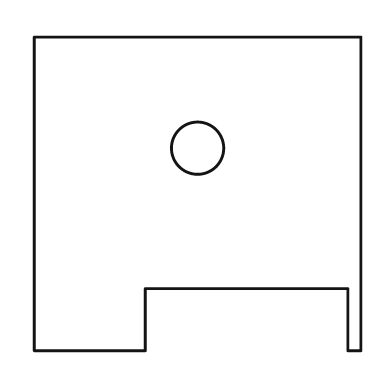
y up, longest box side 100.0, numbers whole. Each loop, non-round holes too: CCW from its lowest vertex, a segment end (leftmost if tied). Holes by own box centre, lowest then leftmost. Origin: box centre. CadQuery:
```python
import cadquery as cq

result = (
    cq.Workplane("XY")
    .moveTo(-50.0, -48.0)
    .lineTo(-16.0, -48.0)
    .lineTo(-16.0, -29.0)
    .lineTo(46.0, -29.0)
    .lineTo(46.0, -48.0)
    .lineTo(50.0, -48.0)
    .lineTo(50.0, 48.0)
    .lineTo(-50.0, 48.0)
    .close()
    .moveTo(0.0, 14.0)
    .circle(8.0)
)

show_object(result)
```